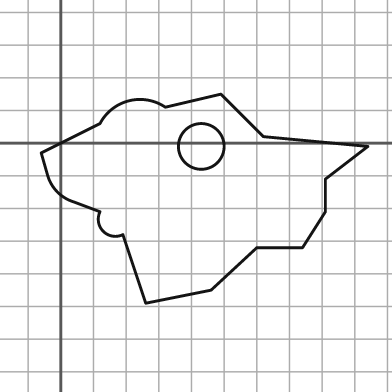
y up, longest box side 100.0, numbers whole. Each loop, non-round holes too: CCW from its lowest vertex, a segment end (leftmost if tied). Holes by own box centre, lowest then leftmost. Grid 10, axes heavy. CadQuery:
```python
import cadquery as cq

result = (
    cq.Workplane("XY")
    .moveTo(26.0, -49.0)
    .lineTo(46.0, -45.0)
    .lineTo(60.0, -32.0)
    .lineTo(74.0, -32.0)
    .lineTo(81.0, -21.0)
    .lineTo(81.0, -11.0)
    .lineTo(94.0, -1.0)
    .lineTo(62.0, 2.0)
    .lineTo(49.0, 15.0)
    .lineTo(32.0, 11.0)
    .threePointArc((21.0, 13.0), (12.0, 6.0))
    .lineTo(-6.0, -3.0)
    .lineTo(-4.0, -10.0)
    .threePointArc((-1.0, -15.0), (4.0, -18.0))
    .lineTo(12.0, -21.0)
    .threePointArc((13.0, -27.0), (19.0, -28.0))
    .close()
    .moveTo(43.0, -1.0)
    .circle(7.0)
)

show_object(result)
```